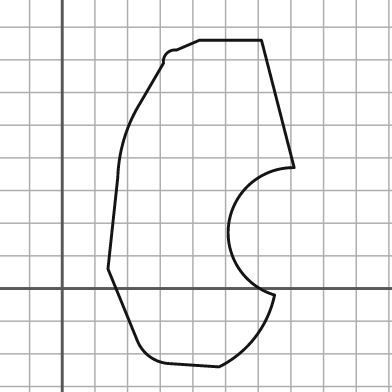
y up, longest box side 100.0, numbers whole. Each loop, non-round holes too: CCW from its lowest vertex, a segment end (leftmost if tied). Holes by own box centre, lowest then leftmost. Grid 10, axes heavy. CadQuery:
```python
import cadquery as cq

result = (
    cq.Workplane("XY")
    .moveTo(48.0, -24.0)
    .threePointArc((59.0, -15.0), (65.0, -2.0))
    .threePointArc((51.0, 20.0), (71.0, 37.0))
    .lineTo(61.0, 76.0)
    .lineTo(42.0, 76.0)
    .lineTo(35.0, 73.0)
    .threePointArc((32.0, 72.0), (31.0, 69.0))
    .lineTo(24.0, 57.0)
    .threePointArc((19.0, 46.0), (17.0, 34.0))
    .lineTo(14.0, 6.0)
    .lineTo(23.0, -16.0)
    .threePointArc((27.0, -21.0), (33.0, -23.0))
    .close()
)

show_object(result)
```